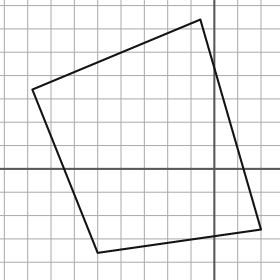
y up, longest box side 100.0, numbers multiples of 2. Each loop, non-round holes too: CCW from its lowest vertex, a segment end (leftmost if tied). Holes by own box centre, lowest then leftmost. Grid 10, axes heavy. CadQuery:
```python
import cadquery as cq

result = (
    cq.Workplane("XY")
    .moveTo(-50.0, -36.0)
    .lineTo(20.0, -26.0)
    .lineTo(-6.0, 64.0)
    .lineTo(-78.0, 34.0)
    .close()
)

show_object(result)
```